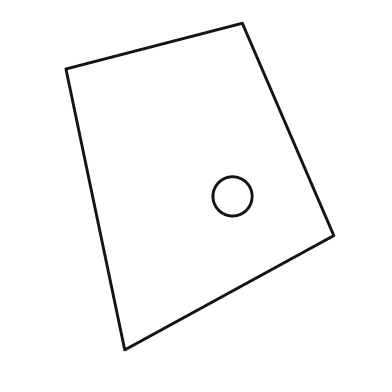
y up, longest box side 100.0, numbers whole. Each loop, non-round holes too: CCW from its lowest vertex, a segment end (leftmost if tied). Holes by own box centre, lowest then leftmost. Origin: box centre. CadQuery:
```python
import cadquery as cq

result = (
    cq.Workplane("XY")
    .moveTo(-23.0, -50.0)
    .lineTo(41.0, -15.0)
    .lineTo(13.0, 50.0)
    .lineTo(-41.0, 36.0)
    .close()
    .moveTo(10.0, -3.0)
    .circle(6.0)
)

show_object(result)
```